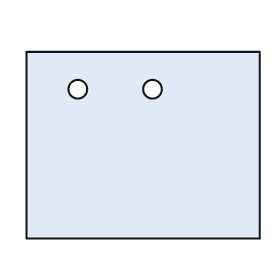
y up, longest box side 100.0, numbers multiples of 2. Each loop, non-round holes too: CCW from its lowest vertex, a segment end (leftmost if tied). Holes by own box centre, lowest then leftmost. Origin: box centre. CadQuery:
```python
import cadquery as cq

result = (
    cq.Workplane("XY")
    .moveTo(-50.0, -40.0)
    .lineTo(50.0, -40.0)
    .lineTo(50.0, 40.0)
    .lineTo(-50.0, 40.0)
    .close()
    .moveTo(-28.0, 24.0)
    .circle(4.0)
    .moveTo(4.0, 24.0)
    .circle(4.0)
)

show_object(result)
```